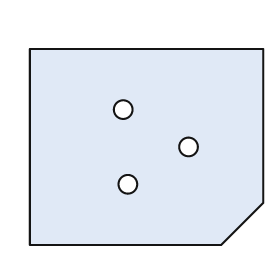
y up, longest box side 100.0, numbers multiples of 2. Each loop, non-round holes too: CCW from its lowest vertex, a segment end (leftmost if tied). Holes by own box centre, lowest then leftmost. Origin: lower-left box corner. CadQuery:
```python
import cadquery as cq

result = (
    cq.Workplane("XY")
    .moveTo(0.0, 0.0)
    .lineTo(82.0, 0.0)
    .lineTo(100.0, 18.0)
    .lineTo(100.0, 84.0)
    .lineTo(0.0, 84.0)
    .close()
    .moveTo(42.0, 26.0)
    .circle(4.0)
    .moveTo(68.0, 42.0)
    .circle(4.0)
    .moveTo(40.0, 58.0)
    .circle(4.0)
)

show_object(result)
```